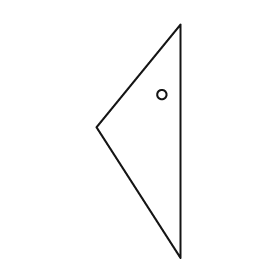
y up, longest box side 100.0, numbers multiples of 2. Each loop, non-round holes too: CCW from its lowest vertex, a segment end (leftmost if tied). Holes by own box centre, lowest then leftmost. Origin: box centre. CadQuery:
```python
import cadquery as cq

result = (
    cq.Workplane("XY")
    .moveTo(18.0, -50.0)
    .lineTo(18.0, 50.0)
    .lineTo(-18.0, 6.0)
    .close()
    .moveTo(10.0, 20.0)
    .circle(2.0)
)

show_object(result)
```